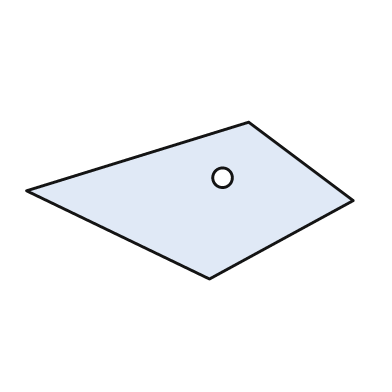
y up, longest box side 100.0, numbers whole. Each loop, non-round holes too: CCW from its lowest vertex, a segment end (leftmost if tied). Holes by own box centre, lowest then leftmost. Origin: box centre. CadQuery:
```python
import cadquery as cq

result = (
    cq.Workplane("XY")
    .moveTo(6.0, -24.0)
    .lineTo(50.0, 0.0)
    .lineTo(18.0, 24.0)
    .lineTo(-50.0, 3.0)
    .close()
    .moveTo(10.0, 7.0)
    .circle(3.0)
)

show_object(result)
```